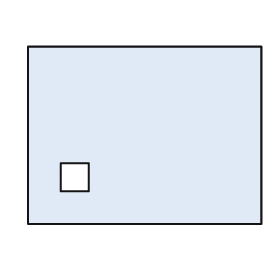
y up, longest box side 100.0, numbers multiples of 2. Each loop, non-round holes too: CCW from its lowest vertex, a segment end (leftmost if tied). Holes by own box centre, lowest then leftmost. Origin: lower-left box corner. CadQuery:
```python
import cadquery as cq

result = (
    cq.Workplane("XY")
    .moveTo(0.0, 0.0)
    .lineTo(100.0, 0.0)
    .lineTo(100.0, 76.0)
    .lineTo(0.0, 76.0)
    .close()
    .moveTo(14.0, 14.0)
    .lineTo(26.0, 14.0)
    .lineTo(26.0, 26.0)
    .lineTo(14.0, 26.0)
    .close()
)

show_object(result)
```